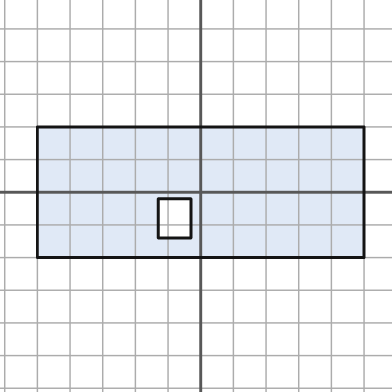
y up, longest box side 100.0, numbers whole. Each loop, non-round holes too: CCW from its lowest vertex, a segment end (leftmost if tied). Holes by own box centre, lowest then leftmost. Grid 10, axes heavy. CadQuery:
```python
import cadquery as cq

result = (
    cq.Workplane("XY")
    .moveTo(-50.0, -20.0)
    .lineTo(50.0, -20.0)
    .lineTo(50.0, 20.0)
    .lineTo(-50.0, 20.0)
    .close()
    .moveTo(-13.0, -14.0)
    .lineTo(-3.0, -14.0)
    .lineTo(-3.0, -2.0)
    .lineTo(-13.0, -2.0)
    .close()
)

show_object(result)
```